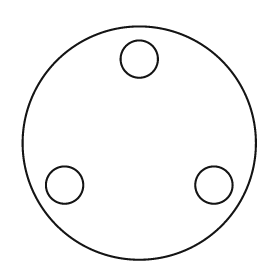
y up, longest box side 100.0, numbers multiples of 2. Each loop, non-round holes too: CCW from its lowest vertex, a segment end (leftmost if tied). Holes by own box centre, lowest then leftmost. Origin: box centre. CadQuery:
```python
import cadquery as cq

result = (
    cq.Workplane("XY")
    .moveTo(0.0, 0.0)
    .circle(50.0)
    .moveTo(-32.0, -18.0)
    .circle(8.0)
    .moveTo(32.0, -18.0)
    .circle(8.0)
    .moveTo(0.0, 36.0)
    .circle(8.0)
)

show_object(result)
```